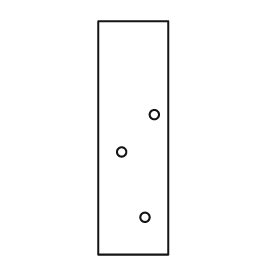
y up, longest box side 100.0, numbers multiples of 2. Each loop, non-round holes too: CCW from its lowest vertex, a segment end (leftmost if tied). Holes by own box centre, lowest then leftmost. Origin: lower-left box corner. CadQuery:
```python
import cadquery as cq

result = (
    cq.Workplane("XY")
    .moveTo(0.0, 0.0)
    .lineTo(30.0, 0.0)
    .lineTo(30.0, 100.0)
    .lineTo(0.0, 100.0)
    .close()
    .moveTo(20.0, 16.0)
    .circle(2.0)
    .moveTo(10.0, 44.0)
    .circle(2.0)
    .moveTo(24.0, 60.0)
    .circle(2.0)
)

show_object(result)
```